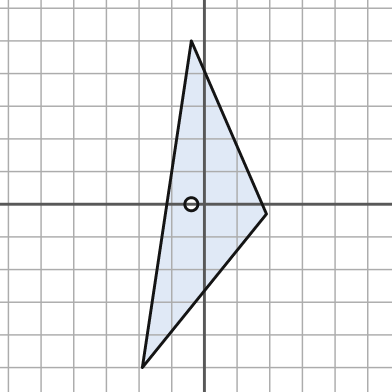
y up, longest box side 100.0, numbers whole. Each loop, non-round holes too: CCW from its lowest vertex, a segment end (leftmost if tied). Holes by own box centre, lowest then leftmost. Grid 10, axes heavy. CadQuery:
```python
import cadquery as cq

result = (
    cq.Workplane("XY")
    .moveTo(-19.0, -50.0)
    .lineTo(19.0, -3.0)
    .lineTo(-4.0, 50.0)
    .close()
    .moveTo(-4.0, 0.0)
    .circle(2.0)
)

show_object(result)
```